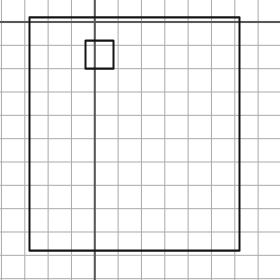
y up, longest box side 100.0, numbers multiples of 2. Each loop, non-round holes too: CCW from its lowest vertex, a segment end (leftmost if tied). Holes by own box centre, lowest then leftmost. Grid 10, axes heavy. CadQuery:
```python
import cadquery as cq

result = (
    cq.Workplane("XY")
    .moveTo(-28.0, -98.0)
    .lineTo(62.0, -98.0)
    .lineTo(62.0, 2.0)
    .lineTo(-28.0, 2.0)
    .close()
    .moveTo(-4.0, -20.0)
    .lineTo(8.0, -20.0)
    .lineTo(8.0, -8.0)
    .lineTo(-4.0, -8.0)
    .close()
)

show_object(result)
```